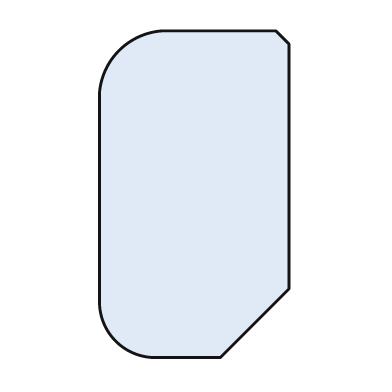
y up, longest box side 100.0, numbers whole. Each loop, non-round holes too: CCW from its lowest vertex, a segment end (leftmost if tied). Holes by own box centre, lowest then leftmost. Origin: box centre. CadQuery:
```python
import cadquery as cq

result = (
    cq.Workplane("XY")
    .moveTo(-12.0, -50.0)
    .lineTo(8.0, -50.0)
    .lineTo(29.0, -29.0)
    .lineTo(29.0, 46.0)
    .lineTo(25.0, 50.0)
    .lineTo(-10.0, 50.0)
    .threePointArc((-23.0, 44.0), (-29.0, 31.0))
    .lineTo(-29.0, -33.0)
    .threePointArc((-24.0, -45.0), (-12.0, -50.0))
    .close()
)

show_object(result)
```